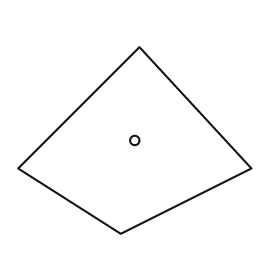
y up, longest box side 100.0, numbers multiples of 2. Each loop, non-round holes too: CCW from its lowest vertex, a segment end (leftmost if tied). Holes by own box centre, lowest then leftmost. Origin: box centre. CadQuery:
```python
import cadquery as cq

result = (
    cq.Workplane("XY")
    .moveTo(-6.0, -40.0)
    .lineTo(50.0, -12.0)
    .lineTo(2.0, 40.0)
    .lineTo(-50.0, -12.0)
    .close()
    .moveTo(0.0, 0.0)
    .circle(2.0)
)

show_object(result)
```